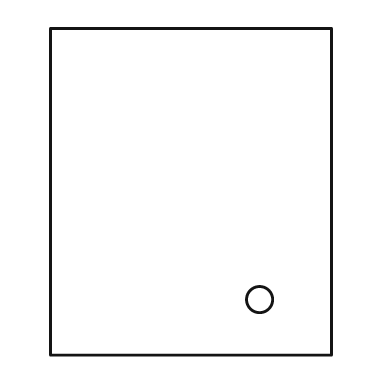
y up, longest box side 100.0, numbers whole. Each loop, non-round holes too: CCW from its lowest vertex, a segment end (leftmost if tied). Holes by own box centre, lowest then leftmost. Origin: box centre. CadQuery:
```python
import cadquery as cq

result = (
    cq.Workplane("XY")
    .moveTo(-43.0, -50.0)
    .lineTo(43.0, -50.0)
    .lineTo(43.0, 50.0)
    .lineTo(-43.0, 50.0)
    .close()
    .moveTo(21.0, -33.0)
    .circle(4.0)
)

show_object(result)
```